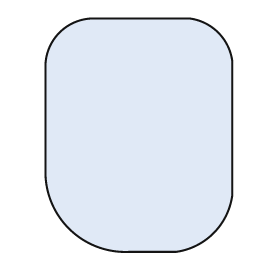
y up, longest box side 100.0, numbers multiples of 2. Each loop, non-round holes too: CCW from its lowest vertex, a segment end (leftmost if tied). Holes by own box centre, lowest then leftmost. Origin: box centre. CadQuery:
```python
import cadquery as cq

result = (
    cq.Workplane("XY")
    .moveTo(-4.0, -50.0)
    .lineTo(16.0, -50.0)
    .threePointArc((32.0, -42.0), (40.0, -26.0))
    .lineTo(40.0, 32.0)
    .threePointArc((34.0, 44.0), (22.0, 50.0))
    .lineTo(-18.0, 50.0)
    .threePointArc((-34.0, 44.0), (-40.0, 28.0))
    .lineTo(-40.0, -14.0)
    .threePointArc((-30.0, -40.0), (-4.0, -50.0))
    .close()
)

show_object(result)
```